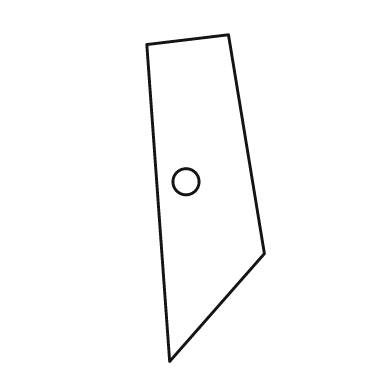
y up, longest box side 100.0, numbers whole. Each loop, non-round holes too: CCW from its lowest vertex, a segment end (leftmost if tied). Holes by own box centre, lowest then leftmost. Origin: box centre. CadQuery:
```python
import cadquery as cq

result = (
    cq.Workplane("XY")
    .moveTo(-11.0, -50.0)
    .lineTo(18.0, -17.0)
    .lineTo(7.0, 50.0)
    .lineTo(-18.0, 47.0)
    .close()
    .moveTo(-6.0, 5.0)
    .circle(4.0)
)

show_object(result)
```